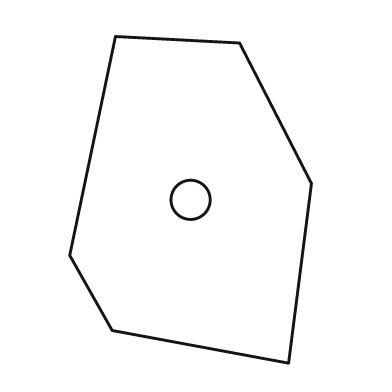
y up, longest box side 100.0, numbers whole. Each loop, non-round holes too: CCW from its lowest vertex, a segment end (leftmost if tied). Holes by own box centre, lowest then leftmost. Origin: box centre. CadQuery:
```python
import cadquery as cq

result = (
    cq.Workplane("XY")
    .moveTo(30.0, -50.0)
    .lineTo(37.0, 5.0)
    .lineTo(15.0, 48.0)
    .lineTo(-23.0, 50.0)
    .lineTo(-37.0, -17.0)
    .lineTo(-24.0, -40.0)
    .close()
    .moveTo(0.0, 0.0)
    .circle(6.0)
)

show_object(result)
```